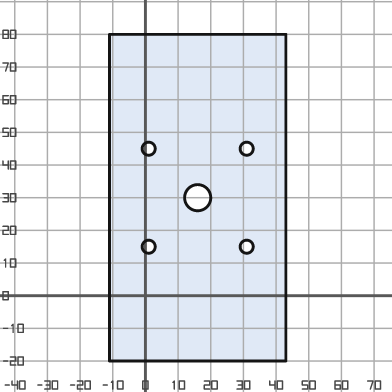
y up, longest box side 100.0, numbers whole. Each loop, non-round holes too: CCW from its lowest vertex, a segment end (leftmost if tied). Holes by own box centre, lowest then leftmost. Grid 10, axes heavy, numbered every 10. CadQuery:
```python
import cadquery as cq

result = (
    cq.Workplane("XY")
    .moveTo(-11.0, -20.0)
    .lineTo(43.0, -20.0)
    .lineTo(43.0, 80.0)
    .lineTo(-11.0, 80.0)
    .close()
    .moveTo(1.0, 15.0)
    .circle(2.0)
    .moveTo(31.0, 15.0)
    .circle(2.0)
    .moveTo(16.0, 30.0)
    .circle(4.0)
    .moveTo(1.0, 45.0)
    .circle(2.0)
    .moveTo(31.0, 45.0)
    .circle(2.0)
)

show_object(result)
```